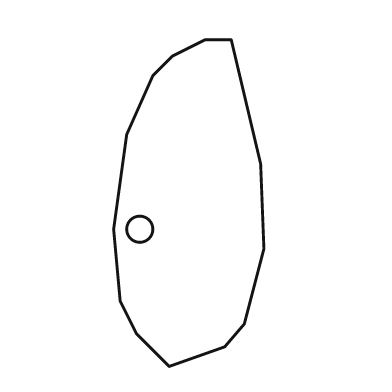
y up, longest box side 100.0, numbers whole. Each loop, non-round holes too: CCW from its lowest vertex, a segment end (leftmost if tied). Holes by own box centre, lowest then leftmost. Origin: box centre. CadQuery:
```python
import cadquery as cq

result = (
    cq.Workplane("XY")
    .moveTo(-6.0, -50.0)
    .lineTo(11.0, -44.0)
    .lineTo(17.0, -37.0)
    .lineTo(23.0, -14.0)
    .lineTo(22.0, 12.0)
    .lineTo(13.0, 50.0)
    .lineTo(5.0, 50.0)
    .lineTo(-5.0, 45.0)
    .lineTo(-11.0, 39.0)
    .lineTo(-19.0, 21.0)
    .lineTo(-23.0, -8.0)
    .lineTo(-21.0, -30.0)
    .lineTo(-16.0, -40.0)
    .close()
    .moveTo(-15.0, -8.0)
    .circle(4.0)
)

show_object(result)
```